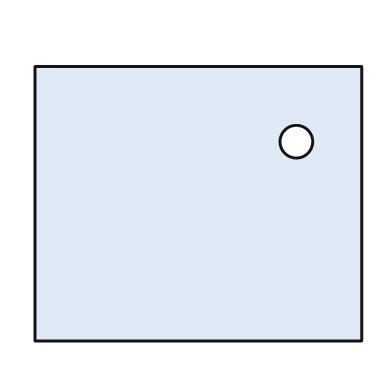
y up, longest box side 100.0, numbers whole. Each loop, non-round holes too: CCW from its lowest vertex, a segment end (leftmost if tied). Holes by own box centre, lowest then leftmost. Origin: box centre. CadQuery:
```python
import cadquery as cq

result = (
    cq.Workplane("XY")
    .moveTo(-50.0, -42.0)
    .lineTo(50.0, -42.0)
    .lineTo(50.0, 42.0)
    .lineTo(-50.0, 42.0)
    .close()
    .moveTo(30.0, 19.0)
    .circle(5.0)
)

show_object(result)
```